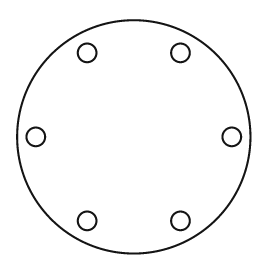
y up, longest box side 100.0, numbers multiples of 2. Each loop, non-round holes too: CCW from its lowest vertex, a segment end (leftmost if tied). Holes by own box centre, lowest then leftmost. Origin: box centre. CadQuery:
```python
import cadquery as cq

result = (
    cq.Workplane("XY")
    .moveTo(0.0, 0.0)
    .circle(50.0)
    .moveTo(-20.0, -36.0)
    .circle(4.0)
    .moveTo(20.0, -36.0)
    .circle(4.0)
    .moveTo(-42.0, 0.0)
    .circle(4.0)
    .moveTo(42.0, 0.0)
    .circle(4.0)
    .moveTo(-20.0, 36.0)
    .circle(4.0)
    .moveTo(20.0, 36.0)
    .circle(4.0)
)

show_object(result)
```